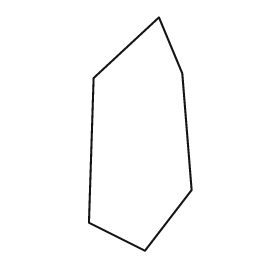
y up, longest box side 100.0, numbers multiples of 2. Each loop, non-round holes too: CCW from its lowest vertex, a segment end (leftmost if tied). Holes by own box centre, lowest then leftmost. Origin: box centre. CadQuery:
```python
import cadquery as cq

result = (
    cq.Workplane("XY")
    .moveTo(2.0, -50.0)
    .lineTo(22.0, -24.0)
    .lineTo(18.0, 26.0)
    .lineTo(8.0, 50.0)
    .lineTo(-20.0, 24.0)
    .lineTo(-22.0, -38.0)
    .close()
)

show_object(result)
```